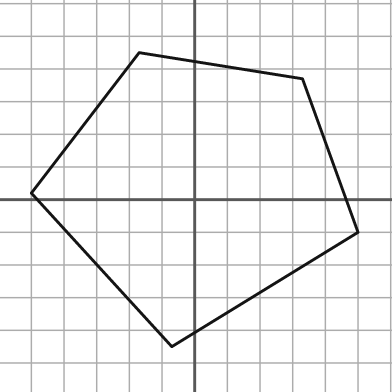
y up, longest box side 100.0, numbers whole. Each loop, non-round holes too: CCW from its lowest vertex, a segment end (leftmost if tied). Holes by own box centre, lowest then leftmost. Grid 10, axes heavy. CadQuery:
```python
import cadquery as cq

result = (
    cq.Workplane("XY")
    .moveTo(-7.0, -45.0)
    .lineTo(50.0, -10.0)
    .lineTo(33.0, 37.0)
    .lineTo(-17.0, 45.0)
    .lineTo(-50.0, 2.0)
    .close()
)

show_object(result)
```